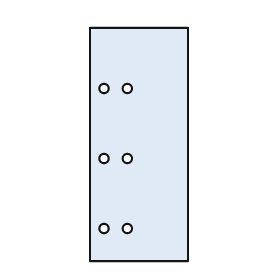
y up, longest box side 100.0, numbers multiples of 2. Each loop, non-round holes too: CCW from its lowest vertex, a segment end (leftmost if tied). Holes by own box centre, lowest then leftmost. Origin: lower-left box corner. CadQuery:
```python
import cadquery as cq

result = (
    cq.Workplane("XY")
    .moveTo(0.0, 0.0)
    .lineTo(42.0, 0.0)
    .lineTo(42.0, 100.0)
    .lineTo(0.0, 100.0)
    .close()
    .moveTo(6.0, 14.0)
    .circle(2.0)
    .moveTo(16.0, 14.0)
    .circle(2.0)
    .moveTo(6.0, 44.0)
    .circle(2.0)
    .moveTo(16.0, 44.0)
    .circle(2.0)
    .moveTo(6.0, 74.0)
    .circle(2.0)
    .moveTo(16.0, 74.0)
    .circle(2.0)
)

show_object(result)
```